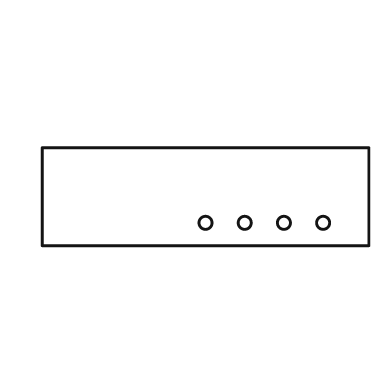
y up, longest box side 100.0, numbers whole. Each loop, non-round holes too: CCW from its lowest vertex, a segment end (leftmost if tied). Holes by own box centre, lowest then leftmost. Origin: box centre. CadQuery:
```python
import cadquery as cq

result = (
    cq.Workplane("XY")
    .moveTo(-50.0, -15.0)
    .lineTo(50.0, -15.0)
    .lineTo(50.0, 15.0)
    .lineTo(-50.0, 15.0)
    .close()
    .moveTo(0.0, -8.0)
    .circle(2.0)
    .moveTo(12.0, -8.0)
    .circle(2.0)
    .moveTo(24.0, -8.0)
    .circle(2.0)
    .moveTo(36.0, -8.0)
    .circle(2.0)
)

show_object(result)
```